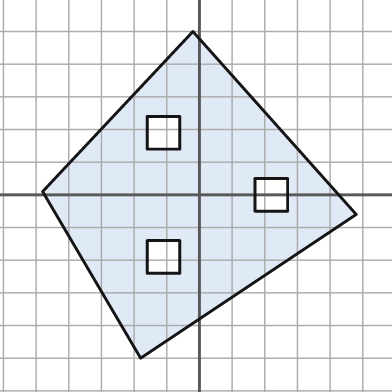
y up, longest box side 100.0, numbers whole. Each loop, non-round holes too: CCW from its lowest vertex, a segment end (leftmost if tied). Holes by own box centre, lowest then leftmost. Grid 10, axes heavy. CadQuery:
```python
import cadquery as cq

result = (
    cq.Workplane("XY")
    .moveTo(-18.0, -50.0)
    .lineTo(48.0, -6.0)
    .lineTo(-2.0, 50.0)
    .lineTo(-48.0, 1.0)
    .close()
    .moveTo(-16.0, -24.0)
    .lineTo(-6.0, -24.0)
    .lineTo(-6.0, -14.0)
    .lineTo(-16.0, -14.0)
    .close()
    .moveTo(17.0, -5.0)
    .lineTo(27.0, -5.0)
    .lineTo(27.0, 5.0)
    .lineTo(17.0, 5.0)
    .close()
    .moveTo(-16.0, 14.0)
    .lineTo(-6.0, 14.0)
    .lineTo(-6.0, 24.0)
    .lineTo(-16.0, 24.0)
    .close()
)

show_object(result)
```